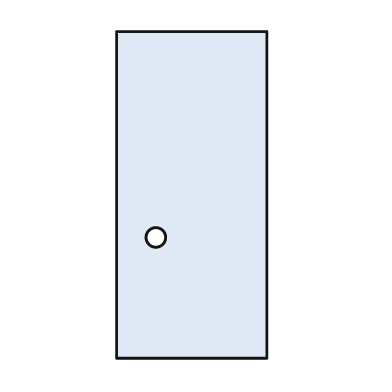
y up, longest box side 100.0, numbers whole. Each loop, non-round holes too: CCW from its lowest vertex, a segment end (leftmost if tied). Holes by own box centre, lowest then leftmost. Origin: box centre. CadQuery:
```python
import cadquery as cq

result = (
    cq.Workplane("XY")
    .moveTo(-23.0, -50.0)
    .lineTo(23.0, -50.0)
    .lineTo(23.0, 50.0)
    .lineTo(-23.0, 50.0)
    .close()
    .moveTo(-11.0, -13.0)
    .circle(3.0)
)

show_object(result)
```